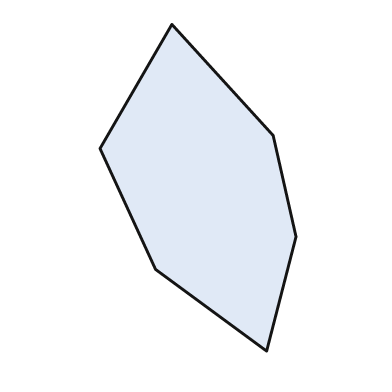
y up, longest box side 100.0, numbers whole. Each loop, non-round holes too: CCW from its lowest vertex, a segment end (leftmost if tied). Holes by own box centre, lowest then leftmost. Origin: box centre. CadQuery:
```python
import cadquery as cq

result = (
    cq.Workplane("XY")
    .moveTo(21.0, -50.0)
    .lineTo(30.0, -15.0)
    .lineTo(23.0, 16.0)
    .lineTo(-8.0, 50.0)
    .lineTo(-30.0, 12.0)
    .lineTo(-13.0, -25.0)
    .close()
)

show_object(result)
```